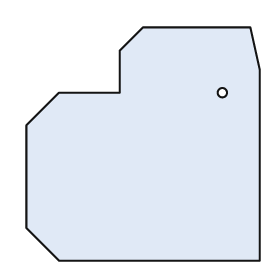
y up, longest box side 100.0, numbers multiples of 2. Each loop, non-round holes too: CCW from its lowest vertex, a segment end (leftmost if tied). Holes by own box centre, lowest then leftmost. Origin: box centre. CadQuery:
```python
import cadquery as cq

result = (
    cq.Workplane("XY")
    .moveTo(-36.0, -50.0)
    .lineTo(50.0, -50.0)
    .lineTo(50.0, 32.0)
    .lineTo(46.0, 50.0)
    .lineTo(0.0, 50.0)
    .lineTo(-10.0, 40.0)
    .lineTo(-10.0, 22.0)
    .lineTo(-36.0, 22.0)
    .lineTo(-50.0, 8.0)
    .lineTo(-50.0, -36.0)
    .close()
    .moveTo(34.0, 22.0)
    .circle(2.0)
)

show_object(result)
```